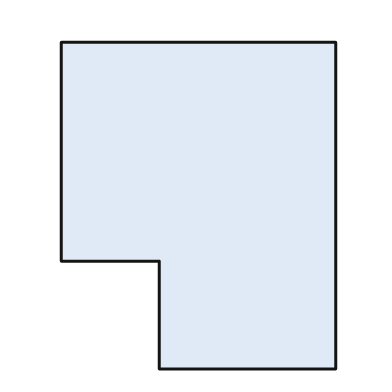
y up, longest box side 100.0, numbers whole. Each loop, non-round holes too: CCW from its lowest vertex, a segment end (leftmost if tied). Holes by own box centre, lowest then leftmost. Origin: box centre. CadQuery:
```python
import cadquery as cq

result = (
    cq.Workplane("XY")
    .moveTo(-12.0, -50.0)
    .lineTo(42.0, -50.0)
    .lineTo(42.0, 50.0)
    .lineTo(-42.0, 50.0)
    .lineTo(-42.0, -17.0)
    .lineTo(-12.0, -17.0)
    .close()
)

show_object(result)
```